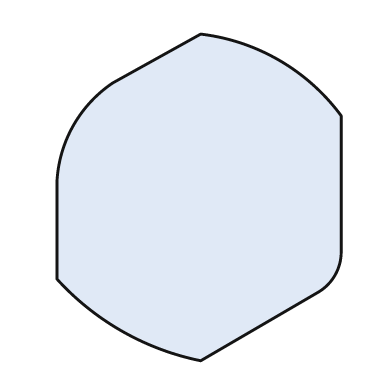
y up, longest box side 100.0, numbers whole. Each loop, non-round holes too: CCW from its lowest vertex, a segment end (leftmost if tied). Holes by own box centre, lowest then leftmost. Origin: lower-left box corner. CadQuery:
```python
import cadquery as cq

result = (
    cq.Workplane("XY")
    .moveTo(44.0, 0.0)
    .lineTo(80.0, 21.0)
    .threePointArc((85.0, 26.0), (87.0, 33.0))
    .lineTo(87.0, 75.0)
    .threePointArc((68.0, 92.0), (44.0, 100.0))
    .lineTo(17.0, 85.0)
    .threePointArc((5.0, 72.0), (0.0, 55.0))
    .lineTo(0.0, 25.0)
    .threePointArc((20.0, 9.0), (44.0, 0.0))
    .close()
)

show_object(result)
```